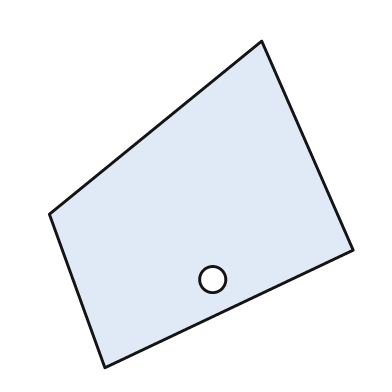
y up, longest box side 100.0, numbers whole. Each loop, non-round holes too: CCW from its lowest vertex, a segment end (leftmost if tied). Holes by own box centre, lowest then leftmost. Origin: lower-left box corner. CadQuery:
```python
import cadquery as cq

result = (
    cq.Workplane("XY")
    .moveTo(17.0, 0.0)
    .lineTo(93.0, 36.0)
    .lineTo(65.0, 100.0)
    .lineTo(0.0, 47.0)
    .close()
    .moveTo(50.0, 27.0)
    .circle(4.0)
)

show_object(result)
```